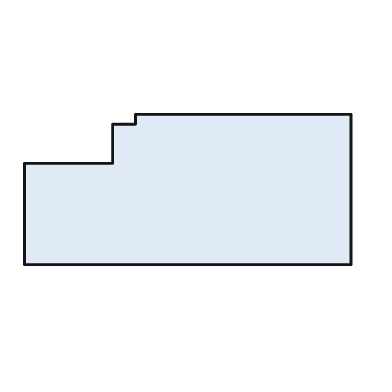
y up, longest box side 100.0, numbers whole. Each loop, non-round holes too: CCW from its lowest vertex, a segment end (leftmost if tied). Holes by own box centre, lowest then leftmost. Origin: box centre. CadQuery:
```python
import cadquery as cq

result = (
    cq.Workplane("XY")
    .moveTo(-50.0, -23.0)
    .lineTo(50.0, -23.0)
    .lineTo(50.0, 23.0)
    .lineTo(-16.0, 23.0)
    .lineTo(-16.0, 20.0)
    .lineTo(-23.0, 20.0)
    .lineTo(-23.0, 8.0)
    .lineTo(-50.0, 8.0)
    .close()
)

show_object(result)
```